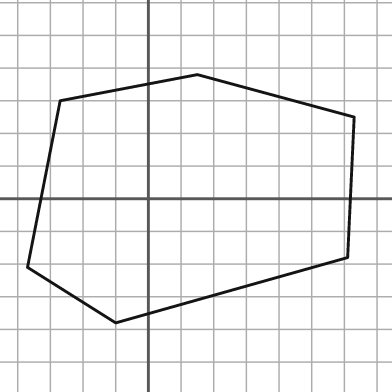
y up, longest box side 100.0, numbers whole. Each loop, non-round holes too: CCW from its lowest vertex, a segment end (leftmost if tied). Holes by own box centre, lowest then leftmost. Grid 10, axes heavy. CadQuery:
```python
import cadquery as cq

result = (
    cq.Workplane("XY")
    .moveTo(-10.0, -38.0)
    .lineTo(61.0, -18.0)
    .lineTo(63.0, 25.0)
    .lineTo(15.0, 38.0)
    .lineTo(-27.0, 30.0)
    .lineTo(-37.0, -21.0)
    .close()
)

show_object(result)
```